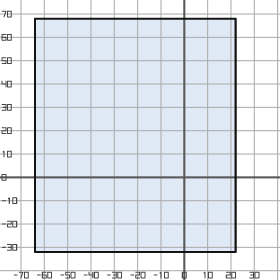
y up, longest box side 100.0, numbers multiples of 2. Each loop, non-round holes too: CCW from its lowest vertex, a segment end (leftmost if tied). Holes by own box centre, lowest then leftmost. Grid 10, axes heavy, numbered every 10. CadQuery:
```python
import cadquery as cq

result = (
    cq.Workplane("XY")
    .moveTo(-64.0, -32.0)
    .lineTo(22.0, -32.0)
    .lineTo(22.0, 68.0)
    .lineTo(-64.0, 68.0)
    .close()
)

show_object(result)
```